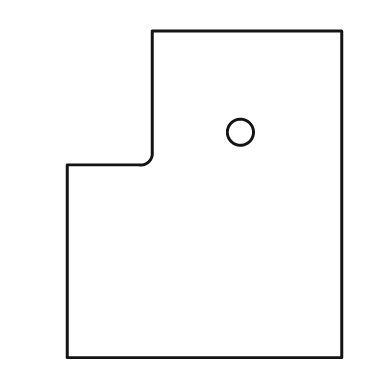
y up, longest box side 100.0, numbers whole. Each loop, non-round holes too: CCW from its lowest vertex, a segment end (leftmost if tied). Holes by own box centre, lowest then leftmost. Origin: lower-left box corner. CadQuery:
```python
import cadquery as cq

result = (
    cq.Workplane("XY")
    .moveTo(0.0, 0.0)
    .lineTo(84.0, 0.0)
    .lineTo(84.0, 100.0)
    .lineTo(26.0, 100.0)
    .lineTo(26.0, 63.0)
    .threePointArc((25.0, 60.0), (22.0, 59.0))
    .lineTo(0.0, 59.0)
    .close()
    .moveTo(53.0, 69.0)
    .circle(4.0)
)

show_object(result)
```